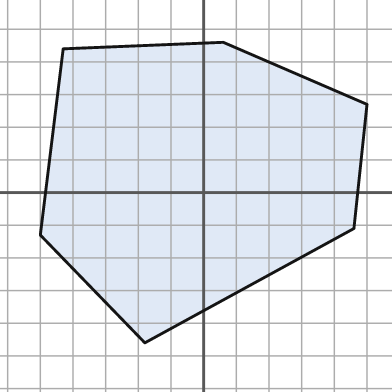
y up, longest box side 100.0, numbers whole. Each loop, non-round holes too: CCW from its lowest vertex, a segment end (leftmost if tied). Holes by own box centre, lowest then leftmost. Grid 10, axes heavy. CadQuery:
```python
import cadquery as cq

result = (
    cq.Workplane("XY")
    .moveTo(-18.0, -46.0)
    .lineTo(46.0, -11.0)
    .lineTo(50.0, 27.0)
    .lineTo(6.0, 46.0)
    .lineTo(-43.0, 44.0)
    .lineTo(-50.0, -13.0)
    .close()
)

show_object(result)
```